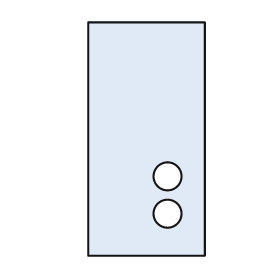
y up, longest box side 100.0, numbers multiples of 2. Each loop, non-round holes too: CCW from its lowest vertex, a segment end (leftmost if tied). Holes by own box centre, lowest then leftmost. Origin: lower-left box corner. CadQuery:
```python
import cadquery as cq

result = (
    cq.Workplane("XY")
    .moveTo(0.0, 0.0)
    .lineTo(50.0, 0.0)
    .lineTo(50.0, 100.0)
    .lineTo(0.0, 100.0)
    .close()
    .moveTo(34.0, 18.0)
    .circle(6.0)
    .moveTo(34.0, 34.0)
    .circle(6.0)
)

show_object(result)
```